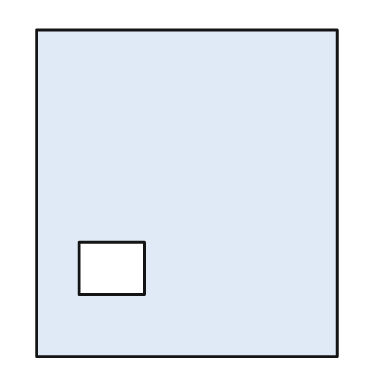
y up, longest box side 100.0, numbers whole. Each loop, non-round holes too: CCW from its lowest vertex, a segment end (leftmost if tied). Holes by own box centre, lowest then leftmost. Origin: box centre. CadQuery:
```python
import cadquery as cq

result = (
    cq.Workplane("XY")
    .moveTo(-46.0, -50.0)
    .lineTo(46.0, -50.0)
    .lineTo(46.0, 50.0)
    .lineTo(-46.0, 50.0)
    .close()
    .moveTo(-33.0, -31.0)
    .lineTo(-13.0, -31.0)
    .lineTo(-13.0, -15.0)
    .lineTo(-33.0, -15.0)
    .close()
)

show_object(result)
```